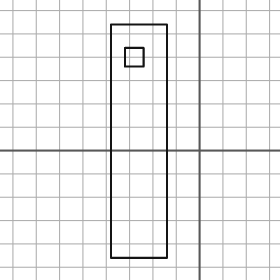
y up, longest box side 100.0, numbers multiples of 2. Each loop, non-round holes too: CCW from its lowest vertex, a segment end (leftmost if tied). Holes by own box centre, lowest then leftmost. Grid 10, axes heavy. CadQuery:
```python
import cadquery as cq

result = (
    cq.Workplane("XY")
    .moveTo(-38.0, -46.0)
    .lineTo(-14.0, -46.0)
    .lineTo(-14.0, 54.0)
    .lineTo(-38.0, 54.0)
    .close()
    .moveTo(-32.0, 36.0)
    .lineTo(-24.0, 36.0)
    .lineTo(-24.0, 44.0)
    .lineTo(-32.0, 44.0)
    .close()
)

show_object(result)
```